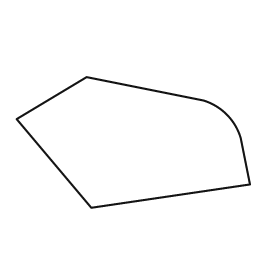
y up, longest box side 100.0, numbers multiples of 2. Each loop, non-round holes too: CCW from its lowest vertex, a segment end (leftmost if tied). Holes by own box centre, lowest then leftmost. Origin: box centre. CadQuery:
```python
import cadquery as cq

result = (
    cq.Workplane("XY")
    .moveTo(-18.0, -28.0)
    .lineTo(50.0, -18.0)
    .lineTo(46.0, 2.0)
    .threePointArc((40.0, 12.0), (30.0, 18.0))
    .lineTo(-20.0, 28.0)
    .lineTo(-50.0, 10.0)
    .close()
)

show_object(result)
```